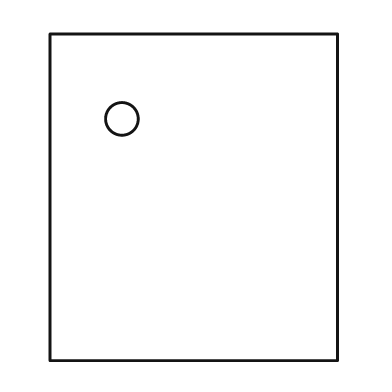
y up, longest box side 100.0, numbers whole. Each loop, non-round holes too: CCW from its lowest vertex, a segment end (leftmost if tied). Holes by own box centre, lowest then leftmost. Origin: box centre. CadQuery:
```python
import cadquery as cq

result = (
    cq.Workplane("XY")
    .moveTo(-44.0, -50.0)
    .lineTo(44.0, -50.0)
    .lineTo(44.0, 50.0)
    .lineTo(-44.0, 50.0)
    .close()
    .moveTo(-22.0, 24.0)
    .circle(5.0)
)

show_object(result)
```